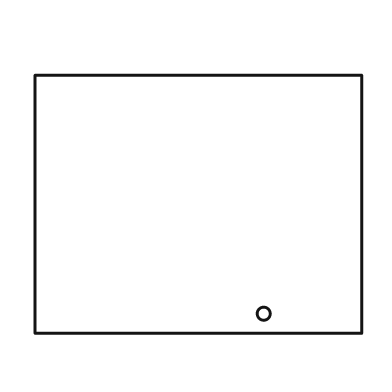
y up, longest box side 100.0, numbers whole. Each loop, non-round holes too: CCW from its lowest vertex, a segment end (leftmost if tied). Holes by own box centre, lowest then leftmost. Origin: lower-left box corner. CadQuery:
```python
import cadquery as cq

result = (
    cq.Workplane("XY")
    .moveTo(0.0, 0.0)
    .lineTo(100.0, 0.0)
    .lineTo(100.0, 79.0)
    .lineTo(0.0, 79.0)
    .close()
    .moveTo(70.0, 6.0)
    .circle(2.0)
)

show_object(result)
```